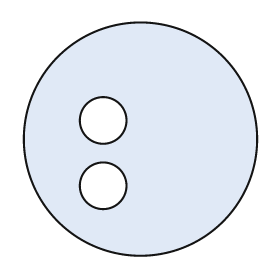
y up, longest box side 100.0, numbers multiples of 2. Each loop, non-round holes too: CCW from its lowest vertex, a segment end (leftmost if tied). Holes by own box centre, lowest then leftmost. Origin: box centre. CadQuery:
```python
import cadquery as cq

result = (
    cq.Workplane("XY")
    .moveTo(0.0, 0.0)
    .circle(50.0)
    .moveTo(-16.0, -20.0)
    .circle(10.0)
    .moveTo(-16.0, 8.0)
    .circle(10.0)
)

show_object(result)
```